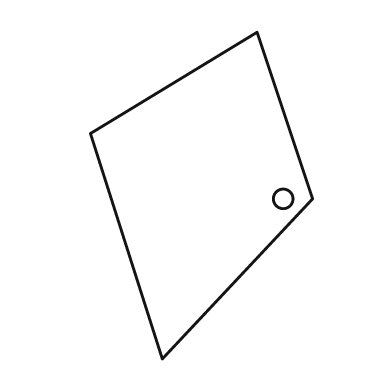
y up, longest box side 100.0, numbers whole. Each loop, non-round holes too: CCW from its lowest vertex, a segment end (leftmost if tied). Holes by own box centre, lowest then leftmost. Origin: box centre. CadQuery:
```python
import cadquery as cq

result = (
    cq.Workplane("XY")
    .moveTo(-12.0, -50.0)
    .lineTo(34.0, -1.0)
    .lineTo(17.0, 50.0)
    .lineTo(-34.0, 19.0)
    .close()
    .moveTo(25.0, -1.0)
    .circle(3.0)
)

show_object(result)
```